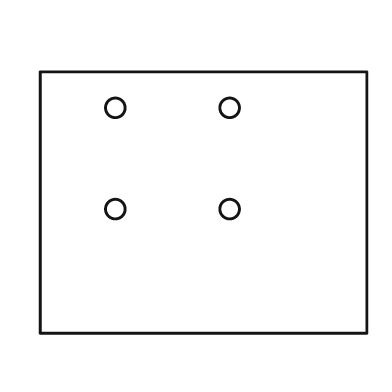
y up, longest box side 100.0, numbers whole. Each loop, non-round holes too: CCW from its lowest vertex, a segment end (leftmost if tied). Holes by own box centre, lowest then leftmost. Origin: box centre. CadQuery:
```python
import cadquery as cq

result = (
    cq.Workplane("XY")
    .moveTo(-50.0, -40.0)
    .lineTo(50.0, -40.0)
    .lineTo(50.0, 40.0)
    .lineTo(-50.0, 40.0)
    .close()
    .moveTo(-27.0, -2.0)
    .circle(3.0)
    .moveTo(8.0, -2.0)
    .circle(3.0)
    .moveTo(-27.0, 29.0)
    .circle(3.0)
    .moveTo(8.0, 29.0)
    .circle(3.0)
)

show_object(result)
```